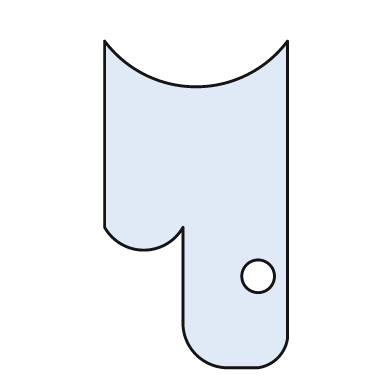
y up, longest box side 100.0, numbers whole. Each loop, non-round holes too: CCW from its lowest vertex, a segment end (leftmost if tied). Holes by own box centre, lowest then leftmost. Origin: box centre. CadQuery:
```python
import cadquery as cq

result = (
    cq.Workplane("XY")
    .moveTo(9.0, -50.0)
    .lineTo(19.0, -50.0)
    .threePointArc((25.0, -47.0), (28.0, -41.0))
    .lineTo(28.0, 50.0)
    .threePointArc((0.0, 36.0), (-28.0, 50.0))
    .lineTo(-28.0, -7.0)
    .threePointArc((-16.0, -14.0), (-4.0, -7.0))
    .lineTo(-4.0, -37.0)
    .threePointArc((0.0, -46.0), (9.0, -50.0))
    .close()
    .moveTo(19.0, -22.0)
    .circle(5.0)
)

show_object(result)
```